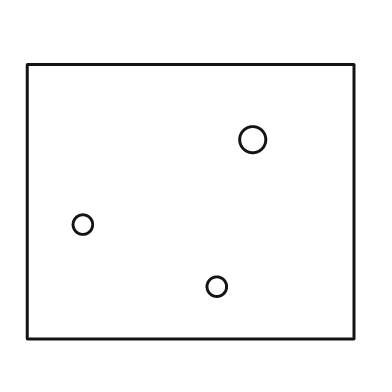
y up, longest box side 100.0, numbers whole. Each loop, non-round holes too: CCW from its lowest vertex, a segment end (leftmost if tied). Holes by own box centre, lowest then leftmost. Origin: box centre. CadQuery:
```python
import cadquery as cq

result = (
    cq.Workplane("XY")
    .moveTo(-50.0, -42.0)
    .lineTo(50.0, -42.0)
    .lineTo(50.0, 42.0)
    .lineTo(-50.0, 42.0)
    .close()
    .moveTo(8.0, -26.0)
    .circle(3.0)
    .moveTo(-33.0, -7.0)
    .circle(3.0)
    .moveTo(19.0, 19.0)
    .circle(4.0)
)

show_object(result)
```